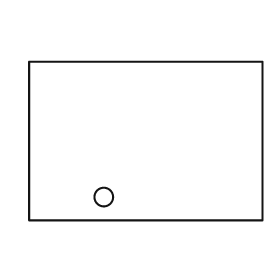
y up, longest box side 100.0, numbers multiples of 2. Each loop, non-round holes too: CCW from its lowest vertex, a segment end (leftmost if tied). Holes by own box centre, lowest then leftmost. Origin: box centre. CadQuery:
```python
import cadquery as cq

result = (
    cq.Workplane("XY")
    .moveTo(-50.0, -34.0)
    .lineTo(50.0, -34.0)
    .lineTo(50.0, 34.0)
    .lineTo(-50.0, 34.0)
    .close()
    .moveTo(-18.0, -24.0)
    .circle(4.0)
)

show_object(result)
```